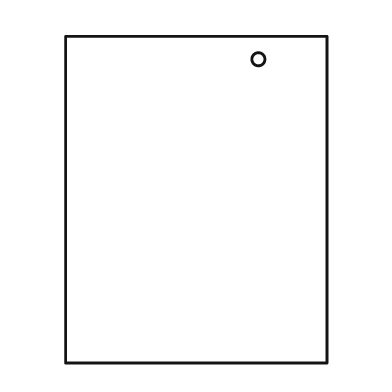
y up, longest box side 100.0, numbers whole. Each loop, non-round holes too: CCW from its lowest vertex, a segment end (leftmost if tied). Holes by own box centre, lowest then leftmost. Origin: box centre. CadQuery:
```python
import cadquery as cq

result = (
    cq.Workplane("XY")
    .moveTo(-40.0, -50.0)
    .lineTo(40.0, -50.0)
    .lineTo(40.0, 50.0)
    .lineTo(-40.0, 50.0)
    .close()
    .moveTo(19.0, 43.0)
    .circle(2.0)
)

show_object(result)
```